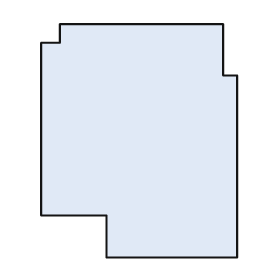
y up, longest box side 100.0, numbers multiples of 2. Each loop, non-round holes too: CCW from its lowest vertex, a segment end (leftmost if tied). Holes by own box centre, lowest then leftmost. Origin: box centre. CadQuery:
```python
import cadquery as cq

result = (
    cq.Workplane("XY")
    .moveTo(-14.0, -50.0)
    .lineTo(42.0, -50.0)
    .lineTo(42.0, 28.0)
    .lineTo(36.0, 28.0)
    .lineTo(36.0, 50.0)
    .lineTo(-34.0, 50.0)
    .lineTo(-34.0, 42.0)
    .lineTo(-42.0, 42.0)
    .lineTo(-42.0, -32.0)
    .lineTo(-14.0, -32.0)
    .close()
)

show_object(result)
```